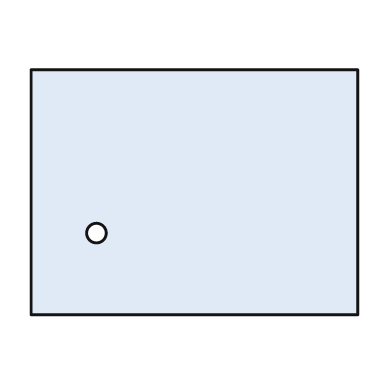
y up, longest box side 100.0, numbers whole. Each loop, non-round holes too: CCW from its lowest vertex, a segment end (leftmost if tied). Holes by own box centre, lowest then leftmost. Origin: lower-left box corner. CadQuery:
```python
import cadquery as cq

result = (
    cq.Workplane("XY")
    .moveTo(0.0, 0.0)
    .lineTo(100.0, 0.0)
    .lineTo(100.0, 75.0)
    .lineTo(0.0, 75.0)
    .close()
    .moveTo(20.0, 25.0)
    .circle(3.0)
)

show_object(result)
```